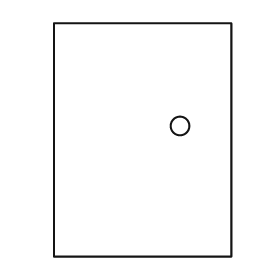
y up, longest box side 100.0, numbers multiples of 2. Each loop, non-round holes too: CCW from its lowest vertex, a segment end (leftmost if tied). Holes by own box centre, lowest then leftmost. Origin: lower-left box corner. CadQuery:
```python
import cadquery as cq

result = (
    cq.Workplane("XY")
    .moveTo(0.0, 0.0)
    .lineTo(76.0, 0.0)
    .lineTo(76.0, 100.0)
    .lineTo(0.0, 100.0)
    .close()
    .moveTo(54.0, 56.0)
    .circle(4.0)
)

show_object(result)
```